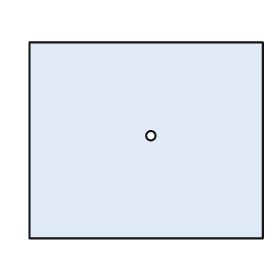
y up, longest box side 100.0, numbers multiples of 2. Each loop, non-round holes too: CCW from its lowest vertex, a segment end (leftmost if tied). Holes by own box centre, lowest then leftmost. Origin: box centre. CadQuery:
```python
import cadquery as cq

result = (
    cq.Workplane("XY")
    .moveTo(-50.0, -42.0)
    .lineTo(50.0, -42.0)
    .lineTo(50.0, 42.0)
    .lineTo(-50.0, 42.0)
    .close()
    .moveTo(2.0, 2.0)
    .circle(2.0)
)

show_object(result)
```